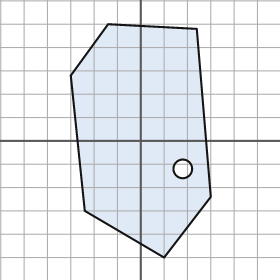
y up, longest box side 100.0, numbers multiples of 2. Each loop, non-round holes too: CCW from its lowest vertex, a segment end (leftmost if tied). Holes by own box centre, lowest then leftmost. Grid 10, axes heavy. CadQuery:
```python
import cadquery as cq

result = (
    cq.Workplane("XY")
    .moveTo(10.0, -50.0)
    .lineTo(30.0, -24.0)
    .lineTo(24.0, 48.0)
    .lineTo(-14.0, 50.0)
    .lineTo(-30.0, 28.0)
    .lineTo(-24.0, -30.0)
    .close()
    .moveTo(18.0, -12.0)
    .circle(4.0)
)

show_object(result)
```